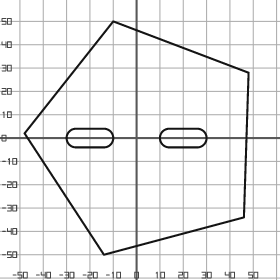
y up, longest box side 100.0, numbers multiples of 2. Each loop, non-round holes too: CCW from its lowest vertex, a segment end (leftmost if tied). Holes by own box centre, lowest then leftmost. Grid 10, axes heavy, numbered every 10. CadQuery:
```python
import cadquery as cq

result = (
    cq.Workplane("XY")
    .moveTo(-14.0, -50.0)
    .lineTo(46.0, -34.0)
    .lineTo(48.0, 28.0)
    .lineTo(-10.0, 50.0)
    .lineTo(-48.0, 2.0)
    .close()
    .moveTo(-26.0, -4.0)
    .lineTo(-14.0, -4.0)
    .threePointArc((-10.0, 0.0), (-14.0, 4.0))
    .lineTo(-26.0, 4.0)
    .threePointArc((-30.0, 0.0), (-26.0, -4.0))
    .close()
    .moveTo(14.0, -4.0)
    .lineTo(26.0, -4.0)
    .threePointArc((30.0, 0.0), (26.0, 4.0))
    .lineTo(14.0, 4.0)
    .threePointArc((10.0, 0.0), (14.0, -4.0))
    .close()
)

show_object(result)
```